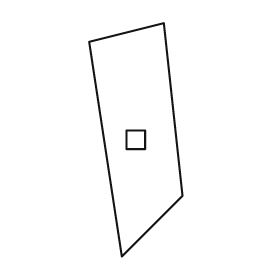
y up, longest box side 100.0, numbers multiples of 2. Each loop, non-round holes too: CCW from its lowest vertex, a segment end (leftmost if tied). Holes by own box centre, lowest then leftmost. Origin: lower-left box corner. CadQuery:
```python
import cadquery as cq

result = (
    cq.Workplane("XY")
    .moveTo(14.0, 0.0)
    .lineTo(40.0, 26.0)
    .lineTo(32.0, 100.0)
    .lineTo(0.0, 92.0)
    .close()
    .moveTo(16.0, 46.0)
    .lineTo(24.0, 46.0)
    .lineTo(24.0, 54.0)
    .lineTo(16.0, 54.0)
    .close()
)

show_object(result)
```